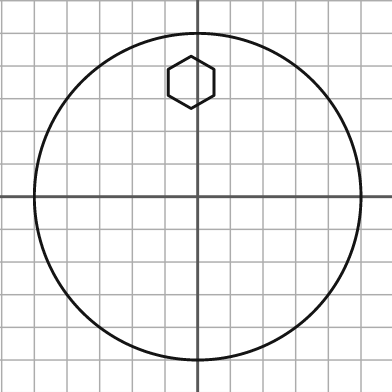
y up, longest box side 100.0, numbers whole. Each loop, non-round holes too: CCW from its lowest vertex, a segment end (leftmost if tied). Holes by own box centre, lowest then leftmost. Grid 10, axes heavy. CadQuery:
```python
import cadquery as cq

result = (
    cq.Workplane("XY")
    .moveTo(0.0, 0.0)
    .circle(50.0)
    .moveTo(-2.0, 27.0)
    .lineTo(5.0, 31.0)
    .lineTo(5.0, 39.0)
    .lineTo(-2.0, 43.0)
    .lineTo(-9.0, 39.0)
    .lineTo(-9.0, 31.0)
    .close()
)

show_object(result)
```